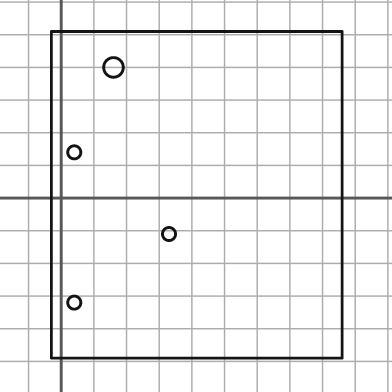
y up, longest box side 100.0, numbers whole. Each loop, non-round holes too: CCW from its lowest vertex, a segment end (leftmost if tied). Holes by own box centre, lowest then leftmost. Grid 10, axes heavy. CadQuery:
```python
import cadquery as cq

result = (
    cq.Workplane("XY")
    .moveTo(-3.0, -49.0)
    .lineTo(86.0, -49.0)
    .lineTo(86.0, 51.0)
    .lineTo(-3.0, 51.0)
    .close()
    .moveTo(4.0, -32.0)
    .circle(2.0)
    .moveTo(33.0, -11.0)
    .circle(2.0)
    .moveTo(4.0, 14.0)
    .circle(2.0)
    .moveTo(16.0, 40.0)
    .circle(3.0)
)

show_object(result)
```